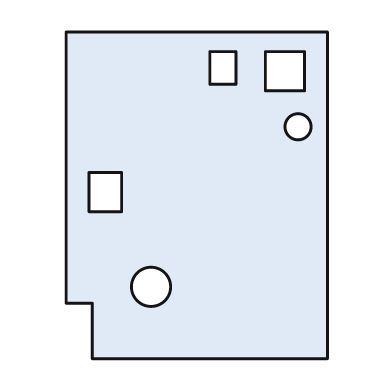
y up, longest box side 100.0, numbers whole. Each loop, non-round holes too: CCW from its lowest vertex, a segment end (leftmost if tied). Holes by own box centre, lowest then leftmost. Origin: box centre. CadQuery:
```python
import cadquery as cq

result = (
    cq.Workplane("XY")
    .moveTo(-32.0, -50.0)
    .lineTo(40.0, -50.0)
    .lineTo(40.0, 50.0)
    .lineTo(-40.0, 50.0)
    .lineTo(-40.0, -33.0)
    .lineTo(-32.0, -33.0)
    .close()
    .moveTo(-14.0, -28.0)
    .circle(6.0)
    .moveTo(-33.0, -5.0)
    .lineTo(-23.0, -5.0)
    .lineTo(-23.0, 7.0)
    .lineTo(-33.0, 7.0)
    .close()
    .moveTo(31.0, 21.0)
    .circle(4.0)
    .moveTo(21.0, 32.0)
    .lineTo(33.0, 32.0)
    .lineTo(33.0, 44.0)
    .lineTo(21.0, 44.0)
    .close()
    .moveTo(4.0, 34.0)
    .lineTo(12.0, 34.0)
    .lineTo(12.0, 44.0)
    .lineTo(4.0, 44.0)
    .close()
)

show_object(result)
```